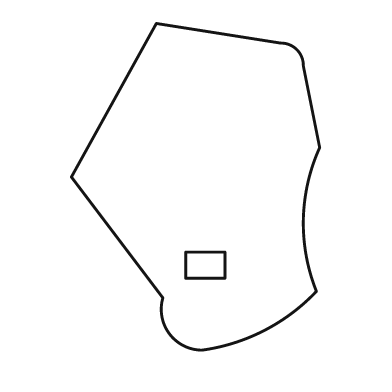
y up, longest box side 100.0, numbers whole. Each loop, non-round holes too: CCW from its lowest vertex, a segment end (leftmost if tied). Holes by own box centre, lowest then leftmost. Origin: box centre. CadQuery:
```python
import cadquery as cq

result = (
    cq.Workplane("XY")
    .moveTo(2.0, -50.0)
    .threePointArc((21.0, -44.0), (37.0, -32.0))
    .threePointArc((33.0, -10.0), (38.0, 12.0))
    .lineTo(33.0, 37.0)
    .threePointArc((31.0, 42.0), (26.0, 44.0))
    .lineTo(-12.0, 50.0)
    .lineTo(-38.0, 3.0)
    .lineTo(-10.0, -34.0)
    .threePointArc((-8.0, -45.0), (2.0, -50.0))
    .close()
    .moveTo(-3.0, -28.0)
    .lineTo(9.0, -28.0)
    .lineTo(9.0, -20.0)
    .lineTo(-3.0, -20.0)
    .close()
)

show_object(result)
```